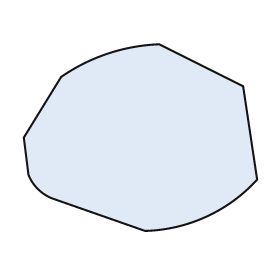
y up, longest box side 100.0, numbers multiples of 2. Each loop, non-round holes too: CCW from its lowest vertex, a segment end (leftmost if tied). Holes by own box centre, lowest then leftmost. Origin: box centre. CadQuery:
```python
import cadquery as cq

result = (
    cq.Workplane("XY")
    .moveTo(2.0, -40.0)
    .threePointArc((28.0, -34.0), (50.0, -18.0))
    .lineTo(44.0, 22.0)
    .lineTo(8.0, 40.0)
    .threePointArc((-14.0, 36.0), (-34.0, 26.0))
    .lineTo(-50.0, 0.0)
    .lineTo(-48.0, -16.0)
    .threePointArc((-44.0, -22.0), (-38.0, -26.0))
    .close()
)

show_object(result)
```